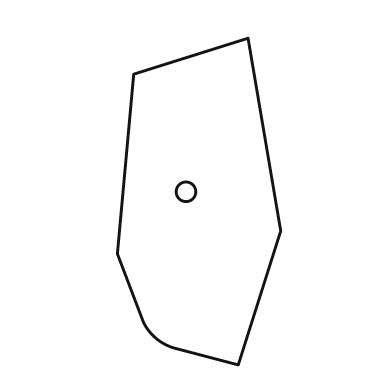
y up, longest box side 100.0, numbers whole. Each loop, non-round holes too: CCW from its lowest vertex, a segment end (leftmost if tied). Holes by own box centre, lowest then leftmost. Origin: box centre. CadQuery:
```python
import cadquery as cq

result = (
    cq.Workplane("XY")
    .moveTo(12.0, -50.0)
    .lineTo(25.0, -9.0)
    .lineTo(15.0, 50.0)
    .lineTo(-20.0, 39.0)
    .lineTo(-25.0, -16.0)
    .lineTo(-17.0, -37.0)
    .threePointArc((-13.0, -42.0), (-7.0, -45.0))
    .close()
    .moveTo(-4.0, 3.0)
    .circle(3.0)
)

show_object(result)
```